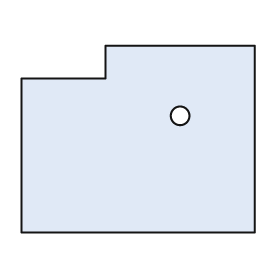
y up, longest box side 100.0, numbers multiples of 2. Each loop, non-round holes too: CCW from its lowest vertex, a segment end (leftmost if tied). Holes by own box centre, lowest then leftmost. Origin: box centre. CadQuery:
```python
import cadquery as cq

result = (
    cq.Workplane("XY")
    .moveTo(-50.0, -40.0)
    .lineTo(50.0, -40.0)
    .lineTo(50.0, 40.0)
    .lineTo(-14.0, 40.0)
    .lineTo(-14.0, 26.0)
    .lineTo(-50.0, 26.0)
    .close()
    .moveTo(18.0, 10.0)
    .circle(4.0)
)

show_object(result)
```